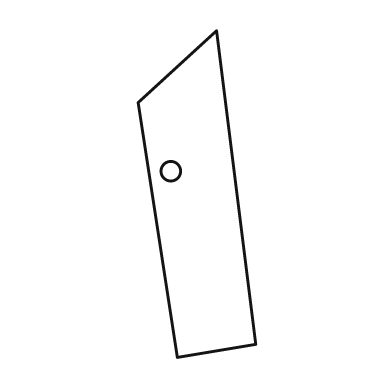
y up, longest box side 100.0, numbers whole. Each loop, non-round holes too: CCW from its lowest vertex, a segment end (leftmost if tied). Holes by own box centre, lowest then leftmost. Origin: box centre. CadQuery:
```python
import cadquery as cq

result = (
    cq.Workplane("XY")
    .moveTo(-6.0, -50.0)
    .lineTo(18.0, -46.0)
    .lineTo(6.0, 50.0)
    .lineTo(-18.0, 28.0)
    .close()
    .moveTo(-8.0, 7.0)
    .circle(3.0)
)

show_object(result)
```